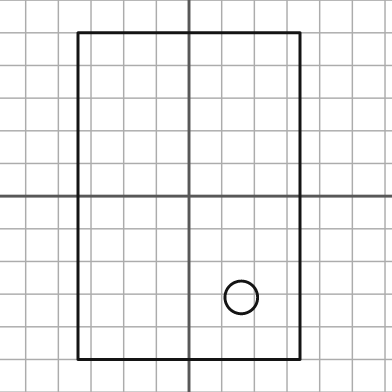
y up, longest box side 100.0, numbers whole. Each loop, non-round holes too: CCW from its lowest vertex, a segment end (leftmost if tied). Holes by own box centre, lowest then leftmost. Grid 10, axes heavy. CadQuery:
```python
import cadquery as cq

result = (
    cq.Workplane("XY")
    .moveTo(-34.0, -50.0)
    .lineTo(34.0, -50.0)
    .lineTo(34.0, 50.0)
    .lineTo(-34.0, 50.0)
    .close()
    .moveTo(16.0, -31.0)
    .circle(5.0)
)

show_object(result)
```